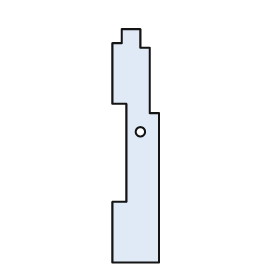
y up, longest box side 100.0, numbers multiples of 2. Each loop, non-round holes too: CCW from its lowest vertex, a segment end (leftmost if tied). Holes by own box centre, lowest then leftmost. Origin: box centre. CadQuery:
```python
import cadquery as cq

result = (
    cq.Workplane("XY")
    .moveTo(-10.0, -50.0)
    .lineTo(10.0, -50.0)
    .lineTo(10.0, 14.0)
    .lineTo(6.0, 14.0)
    .lineTo(6.0, 42.0)
    .lineTo(2.0, 42.0)
    .lineTo(2.0, 50.0)
    .lineTo(-6.0, 50.0)
    .lineTo(-6.0, 44.0)
    .lineTo(-10.0, 44.0)
    .lineTo(-10.0, 18.0)
    .lineTo(-4.0, 18.0)
    .lineTo(-4.0, -24.0)
    .lineTo(-10.0, -24.0)
    .close()
    .moveTo(2.0, 6.0)
    .circle(2.0)
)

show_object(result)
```